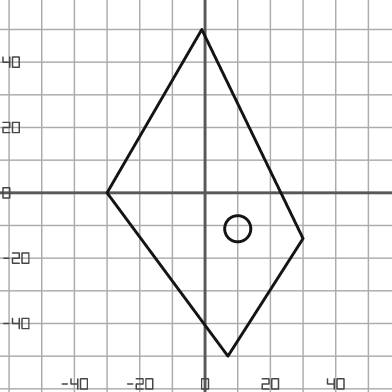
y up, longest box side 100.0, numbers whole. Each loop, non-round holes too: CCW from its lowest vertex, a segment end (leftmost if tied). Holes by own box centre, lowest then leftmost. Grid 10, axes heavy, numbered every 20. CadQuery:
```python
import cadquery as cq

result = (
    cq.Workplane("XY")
    .moveTo(7.0, -50.0)
    .lineTo(30.0, -14.0)
    .lineTo(-1.0, 50.0)
    .lineTo(-30.0, 0.0)
    .close()
    .moveTo(10.0, -11.0)
    .circle(4.0)
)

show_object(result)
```